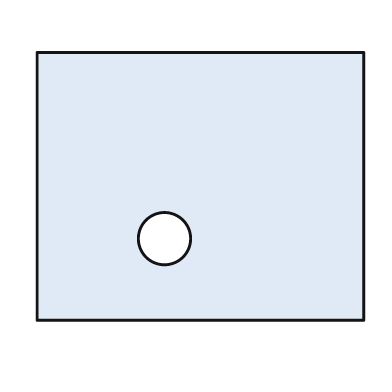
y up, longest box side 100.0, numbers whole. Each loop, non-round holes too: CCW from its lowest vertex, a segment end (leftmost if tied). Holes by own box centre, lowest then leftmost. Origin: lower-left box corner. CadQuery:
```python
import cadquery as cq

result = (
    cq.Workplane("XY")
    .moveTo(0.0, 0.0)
    .lineTo(100.0, 0.0)
    .lineTo(100.0, 82.0)
    .lineTo(0.0, 82.0)
    .close()
    .moveTo(39.0, 25.0)
    .circle(8.0)
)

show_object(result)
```